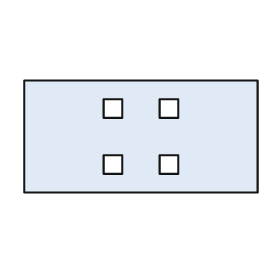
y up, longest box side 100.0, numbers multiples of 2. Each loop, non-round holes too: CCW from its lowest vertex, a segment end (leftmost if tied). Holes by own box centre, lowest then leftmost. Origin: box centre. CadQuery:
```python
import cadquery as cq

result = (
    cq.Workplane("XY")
    .moveTo(-50.0, -24.0)
    .lineTo(50.0, -24.0)
    .lineTo(50.0, 24.0)
    .lineTo(-50.0, 24.0)
    .close()
    .moveTo(-16.0, -16.0)
    .lineTo(-8.0, -16.0)
    .lineTo(-8.0, -8.0)
    .lineTo(-16.0, -8.0)
    .close()
    .moveTo(8.0, -16.0)
    .lineTo(16.0, -16.0)
    .lineTo(16.0, -8.0)
    .lineTo(8.0, -8.0)
    .close()
    .moveTo(-16.0, 8.0)
    .lineTo(-8.0, 8.0)
    .lineTo(-8.0, 16.0)
    .lineTo(-16.0, 16.0)
    .close()
    .moveTo(8.0, 8.0)
    .lineTo(16.0, 8.0)
    .lineTo(16.0, 16.0)
    .lineTo(8.0, 16.0)
    .close()
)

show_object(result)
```